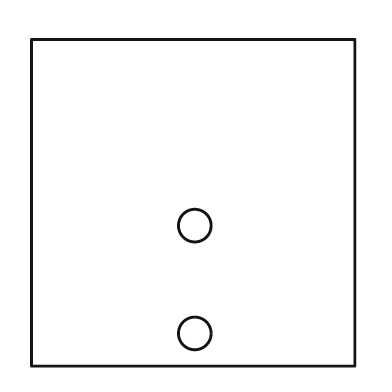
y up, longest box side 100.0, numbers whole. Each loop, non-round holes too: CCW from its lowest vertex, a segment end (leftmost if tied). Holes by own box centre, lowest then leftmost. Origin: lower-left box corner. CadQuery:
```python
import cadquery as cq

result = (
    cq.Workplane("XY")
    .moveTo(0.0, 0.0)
    .lineTo(99.0, 0.0)
    .lineTo(99.0, 100.0)
    .lineTo(0.0, 100.0)
    .close()
    .moveTo(50.0, 10.0)
    .circle(5.0)
    .moveTo(50.0, 43.0)
    .circle(5.0)
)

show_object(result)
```